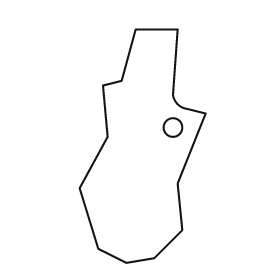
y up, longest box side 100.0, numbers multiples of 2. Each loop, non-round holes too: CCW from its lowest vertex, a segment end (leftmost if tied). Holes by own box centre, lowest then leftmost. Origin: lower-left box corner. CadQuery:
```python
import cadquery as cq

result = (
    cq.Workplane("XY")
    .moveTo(20.0, 0.0)
    .lineTo(32.0, 2.0)
    .lineTo(44.0, 14.0)
    .lineTo(42.0, 34.0)
    .lineTo(54.0, 64.0)
    .lineTo(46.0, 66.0)
    .threePointArc((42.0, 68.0), (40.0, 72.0))
    .lineTo(42.0, 100.0)
    .lineTo(24.0, 100.0)
    .lineTo(18.0, 78.0)
    .lineTo(10.0, 76.0)
    .lineTo(12.0, 54.0)
    .lineTo(0.0, 32.0)
    .lineTo(8.0, 6.0)
    .close()
    .moveTo(40.0, 58.0)
    .circle(4.0)
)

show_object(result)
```